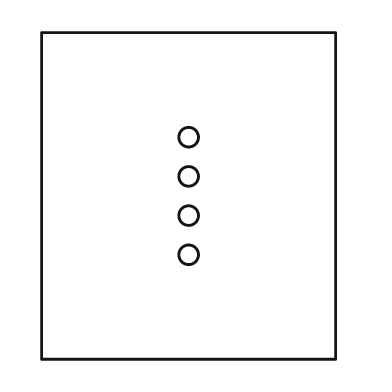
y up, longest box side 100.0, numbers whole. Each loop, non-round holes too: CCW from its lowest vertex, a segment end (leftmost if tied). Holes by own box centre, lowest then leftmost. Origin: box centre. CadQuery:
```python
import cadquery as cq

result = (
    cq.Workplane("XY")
    .moveTo(-45.0, -50.0)
    .lineTo(45.0, -50.0)
    .lineTo(45.0, 50.0)
    .lineTo(-45.0, 50.0)
    .close()
    .moveTo(0.0, -18.0)
    .circle(3.0)
    .moveTo(0.0, -6.0)
    .circle(3.0)
    .moveTo(0.0, 6.0)
    .circle(3.0)
    .moveTo(0.0, 18.0)
    .circle(3.0)
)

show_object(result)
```